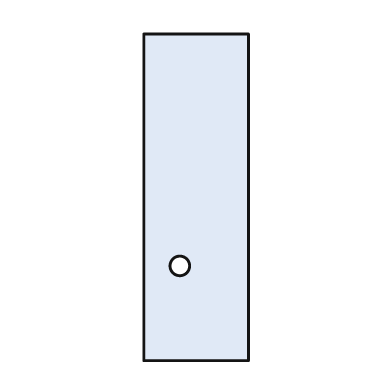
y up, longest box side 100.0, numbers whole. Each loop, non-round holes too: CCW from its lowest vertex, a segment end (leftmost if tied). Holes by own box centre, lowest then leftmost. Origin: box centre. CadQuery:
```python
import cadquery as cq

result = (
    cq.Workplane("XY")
    .moveTo(-16.0, -50.0)
    .lineTo(16.0, -50.0)
    .lineTo(16.0, 50.0)
    .lineTo(-16.0, 50.0)
    .close()
    .moveTo(-5.0, -21.0)
    .circle(3.0)
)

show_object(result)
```